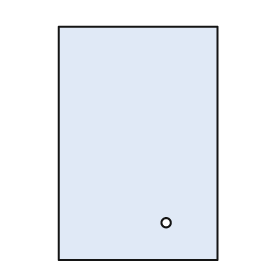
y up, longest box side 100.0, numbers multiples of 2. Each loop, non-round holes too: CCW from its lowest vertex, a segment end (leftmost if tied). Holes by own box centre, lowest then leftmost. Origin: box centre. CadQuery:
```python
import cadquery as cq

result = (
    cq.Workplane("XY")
    .moveTo(-34.0, -50.0)
    .lineTo(34.0, -50.0)
    .lineTo(34.0, 50.0)
    .lineTo(-34.0, 50.0)
    .close()
    .moveTo(12.0, -34.0)
    .circle(2.0)
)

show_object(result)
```